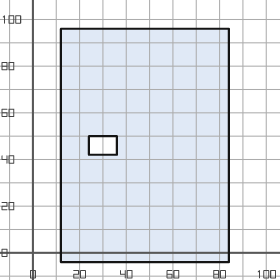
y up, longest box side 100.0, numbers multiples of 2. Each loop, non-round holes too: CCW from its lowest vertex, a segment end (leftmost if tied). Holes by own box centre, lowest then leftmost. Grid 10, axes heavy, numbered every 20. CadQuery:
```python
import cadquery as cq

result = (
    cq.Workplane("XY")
    .moveTo(12.0, -4.0)
    .lineTo(84.0, -4.0)
    .lineTo(84.0, 96.0)
    .lineTo(12.0, 96.0)
    .close()
    .moveTo(24.0, 42.0)
    .lineTo(36.0, 42.0)
    .lineTo(36.0, 50.0)
    .lineTo(24.0, 50.0)
    .close()
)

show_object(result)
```